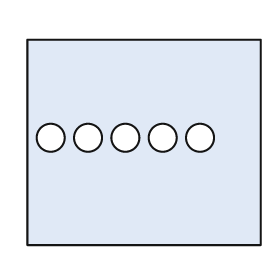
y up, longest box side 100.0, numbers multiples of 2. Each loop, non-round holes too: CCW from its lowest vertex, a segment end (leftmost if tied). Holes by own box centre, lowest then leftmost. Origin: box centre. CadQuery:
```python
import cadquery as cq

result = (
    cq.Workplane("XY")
    .moveTo(-50.0, -44.0)
    .lineTo(50.0, -44.0)
    .lineTo(50.0, 44.0)
    .lineTo(-50.0, 44.0)
    .close()
    .moveTo(-40.0, 2.0)
    .circle(6.0)
    .moveTo(-24.0, 2.0)
    .circle(6.0)
    .moveTo(-8.0, 2.0)
    .circle(6.0)
    .moveTo(8.0, 2.0)
    .circle(6.0)
    .moveTo(24.0, 2.0)
    .circle(6.0)
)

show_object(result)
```